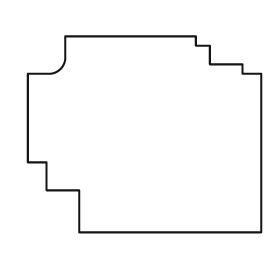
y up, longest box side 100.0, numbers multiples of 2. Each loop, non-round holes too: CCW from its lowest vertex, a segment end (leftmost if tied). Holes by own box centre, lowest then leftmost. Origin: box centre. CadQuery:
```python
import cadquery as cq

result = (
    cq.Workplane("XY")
    .moveTo(-28.0, -42.0)
    .lineTo(50.0, -42.0)
    .lineTo(50.0, 26.0)
    .lineTo(42.0, 26.0)
    .lineTo(42.0, 30.0)
    .lineTo(28.0, 30.0)
    .lineTo(28.0, 38.0)
    .lineTo(22.0, 38.0)
    .lineTo(22.0, 42.0)
    .lineTo(-34.0, 42.0)
    .lineTo(-34.0, 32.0)
    .threePointArc((-36.0, 28.0), (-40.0, 26.0))
    .lineTo(-50.0, 26.0)
    .lineTo(-50.0, -12.0)
    .lineTo(-42.0, -12.0)
    .lineTo(-42.0, -24.0)
    .lineTo(-28.0, -24.0)
    .close()
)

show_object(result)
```